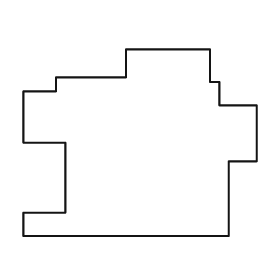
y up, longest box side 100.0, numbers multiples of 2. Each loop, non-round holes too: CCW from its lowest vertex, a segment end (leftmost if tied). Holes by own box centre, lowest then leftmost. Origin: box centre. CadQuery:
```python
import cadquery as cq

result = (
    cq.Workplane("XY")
    .moveTo(-50.0, -40.0)
    .lineTo(38.0, -40.0)
    .lineTo(38.0, -8.0)
    .lineTo(50.0, -8.0)
    .lineTo(50.0, 16.0)
    .lineTo(34.0, 16.0)
    .lineTo(34.0, 26.0)
    .lineTo(30.0, 26.0)
    .lineTo(30.0, 40.0)
    .lineTo(-6.0, 40.0)
    .lineTo(-6.0, 28.0)
    .lineTo(-36.0, 28.0)
    .lineTo(-36.0, 22.0)
    .lineTo(-50.0, 22.0)
    .lineTo(-50.0, 0.0)
    .lineTo(-32.0, 0.0)
    .lineTo(-32.0, -30.0)
    .lineTo(-50.0, -30.0)
    .close()
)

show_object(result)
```